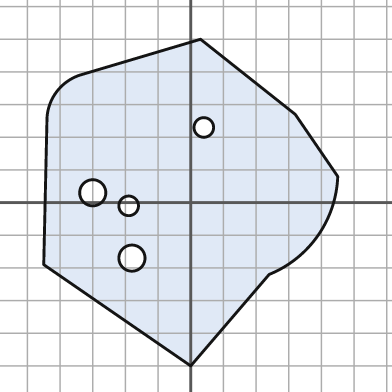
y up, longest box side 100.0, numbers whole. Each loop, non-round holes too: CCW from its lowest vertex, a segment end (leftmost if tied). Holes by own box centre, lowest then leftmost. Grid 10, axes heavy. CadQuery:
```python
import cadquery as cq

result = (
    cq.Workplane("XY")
    .moveTo(0.0, -50.0)
    .lineTo(24.0, -22.0)
    .threePointArc((39.0, -10.0), (45.0, 8.0))
    .lineTo(32.0, 27.0)
    .lineTo(3.0, 50.0)
    .lineTo(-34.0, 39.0)
    .threePointArc((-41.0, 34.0), (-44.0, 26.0))
    .lineTo(-45.0, -19.0)
    .close()
    .moveTo(-18.0, -17.0)
    .circle(4.0)
    .moveTo(-19.0, -1.0)
    .circle(3.0)
    .moveTo(-30.0, 3.0)
    .circle(4.0)
    .moveTo(4.0, 23.0)
    .circle(3.0)
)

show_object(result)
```